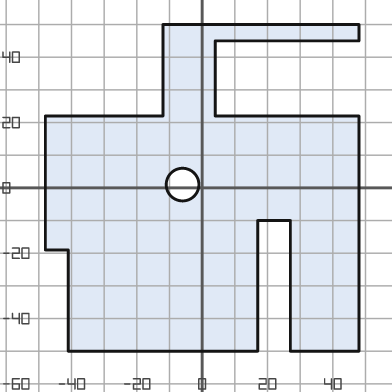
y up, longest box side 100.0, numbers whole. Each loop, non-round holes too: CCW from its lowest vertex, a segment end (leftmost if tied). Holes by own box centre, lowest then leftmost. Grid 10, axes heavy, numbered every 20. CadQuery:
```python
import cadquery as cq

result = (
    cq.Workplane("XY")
    .moveTo(-41.0, -50.0)
    .lineTo(17.0, -50.0)
    .lineTo(17.0, -10.0)
    .lineTo(27.0, -10.0)
    .lineTo(27.0, -50.0)
    .lineTo(48.0, -50.0)
    .lineTo(48.0, 22.0)
    .lineTo(4.0, 22.0)
    .lineTo(4.0, 45.0)
    .lineTo(48.0, 45.0)
    .lineTo(48.0, 50.0)
    .lineTo(-12.0, 50.0)
    .lineTo(-12.0, 22.0)
    .lineTo(-48.0, 22.0)
    .lineTo(-48.0, -19.0)
    .lineTo(-41.0, -19.0)
    .close()
    .moveTo(-6.0, 1.0)
    .circle(5.0)
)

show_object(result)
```